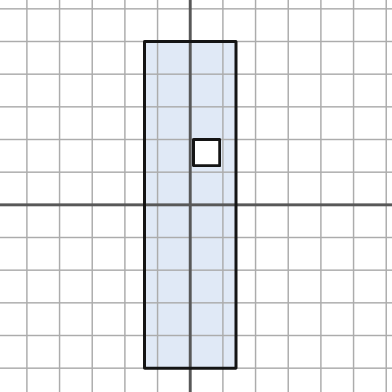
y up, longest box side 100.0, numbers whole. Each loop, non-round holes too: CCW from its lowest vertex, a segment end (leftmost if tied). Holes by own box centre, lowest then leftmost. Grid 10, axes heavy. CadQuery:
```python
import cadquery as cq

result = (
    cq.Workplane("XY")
    .moveTo(-14.0, -50.0)
    .lineTo(14.0, -50.0)
    .lineTo(14.0, 50.0)
    .lineTo(-14.0, 50.0)
    .close()
    .moveTo(1.0, 12.0)
    .lineTo(9.0, 12.0)
    .lineTo(9.0, 20.0)
    .lineTo(1.0, 20.0)
    .close()
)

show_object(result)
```